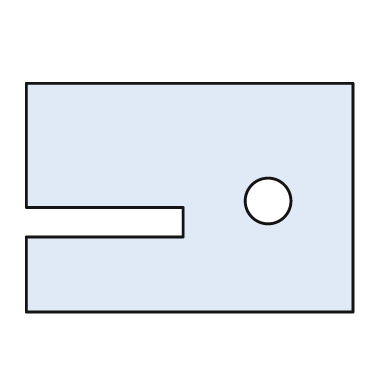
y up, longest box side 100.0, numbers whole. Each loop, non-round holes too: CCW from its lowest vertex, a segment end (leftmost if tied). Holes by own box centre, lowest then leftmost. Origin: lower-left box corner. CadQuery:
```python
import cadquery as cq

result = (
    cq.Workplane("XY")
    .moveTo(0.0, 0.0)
    .lineTo(100.0, 0.0)
    .lineTo(100.0, 70.0)
    .lineTo(0.0, 70.0)
    .lineTo(0.0, 32.0)
    .lineTo(48.0, 32.0)
    .lineTo(48.0, 23.0)
    .lineTo(0.0, 23.0)
    .close()
    .moveTo(74.0, 34.0)
    .circle(7.0)
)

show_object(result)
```